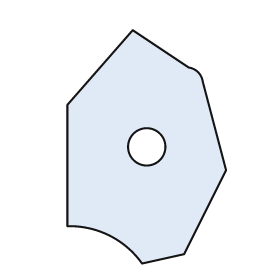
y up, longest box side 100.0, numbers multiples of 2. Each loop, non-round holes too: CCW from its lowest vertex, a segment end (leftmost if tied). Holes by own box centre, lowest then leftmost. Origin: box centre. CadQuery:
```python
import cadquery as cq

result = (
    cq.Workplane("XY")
    .moveTo(-2.0, -50.0)
    .lineTo(16.0, -46.0)
    .lineTo(34.0, -10.0)
    .lineTo(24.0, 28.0)
    .threePointArc((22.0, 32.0), (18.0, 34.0))
    .lineTo(-6.0, 50.0)
    .lineTo(-34.0, 18.0)
    .lineTo(-34.0, -34.0)
    .threePointArc((-16.0, -38.0), (-2.0, -50.0))
    .close()
    .moveTo(0.0, 0.0)
    .circle(8.0)
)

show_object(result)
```